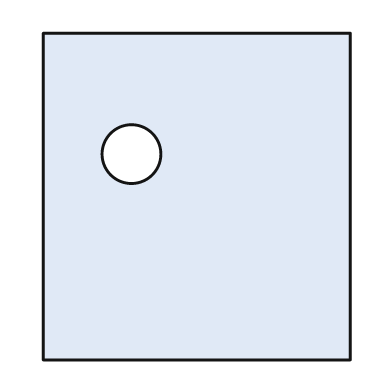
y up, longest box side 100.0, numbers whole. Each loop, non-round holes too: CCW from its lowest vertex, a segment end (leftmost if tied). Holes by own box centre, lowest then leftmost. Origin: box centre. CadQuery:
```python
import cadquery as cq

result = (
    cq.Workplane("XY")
    .moveTo(-47.0, -50.0)
    .lineTo(47.0, -50.0)
    .lineTo(47.0, 50.0)
    .lineTo(-47.0, 50.0)
    .close()
    .moveTo(-20.0, 13.0)
    .circle(9.0)
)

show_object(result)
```